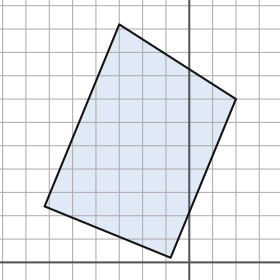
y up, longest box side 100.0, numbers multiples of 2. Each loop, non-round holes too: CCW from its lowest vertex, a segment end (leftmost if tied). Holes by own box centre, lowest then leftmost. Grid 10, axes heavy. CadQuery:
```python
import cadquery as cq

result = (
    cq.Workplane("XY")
    .moveTo(-8.0, 2.0)
    .lineTo(20.0, 70.0)
    .lineTo(-30.0, 102.0)
    .lineTo(-62.0, 24.0)
    .close()
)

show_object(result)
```